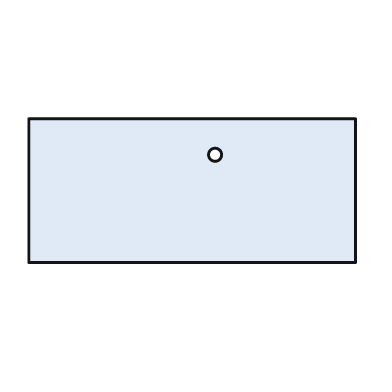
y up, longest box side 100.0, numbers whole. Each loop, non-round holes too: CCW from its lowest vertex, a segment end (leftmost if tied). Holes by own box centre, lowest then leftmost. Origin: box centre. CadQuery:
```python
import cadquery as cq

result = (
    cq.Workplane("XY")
    .moveTo(-50.0, -22.0)
    .lineTo(50.0, -22.0)
    .lineTo(50.0, 22.0)
    .lineTo(-50.0, 22.0)
    .close()
    .moveTo(7.0, 11.0)
    .circle(2.0)
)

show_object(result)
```